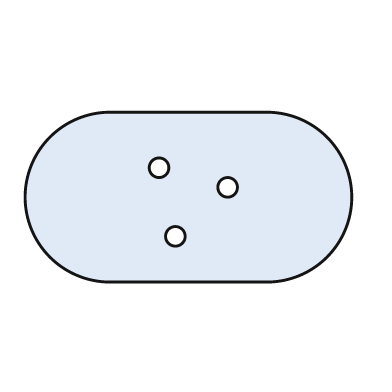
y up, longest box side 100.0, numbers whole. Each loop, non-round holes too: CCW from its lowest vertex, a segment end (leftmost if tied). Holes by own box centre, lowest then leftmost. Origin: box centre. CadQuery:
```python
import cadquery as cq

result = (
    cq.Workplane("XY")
    .moveTo(-24.0, -26.0)
    .lineTo(24.0, -26.0)
    .threePointArc((50.0, 0.0), (24.0, 26.0))
    .lineTo(-24.0, 26.0)
    .threePointArc((-50.0, 0.0), (-24.0, -26.0))
    .close()
    .moveTo(-4.0, -12.0)
    .circle(3.0)
    .moveTo(12.0, 3.0)
    .circle(3.0)
    .moveTo(-9.0, 9.0)
    .circle(3.0)
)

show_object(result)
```